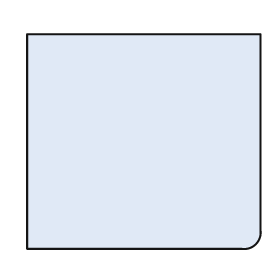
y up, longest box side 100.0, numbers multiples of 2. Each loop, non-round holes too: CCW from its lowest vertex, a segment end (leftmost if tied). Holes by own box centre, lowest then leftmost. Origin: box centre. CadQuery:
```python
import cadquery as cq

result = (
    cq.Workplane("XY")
    .moveTo(-50.0, -46.0)
    .lineTo(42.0, -46.0)
    .threePointArc((48.0, -44.0), (50.0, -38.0))
    .lineTo(50.0, 46.0)
    .lineTo(-50.0, 46.0)
    .close()
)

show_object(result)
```